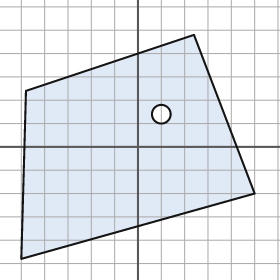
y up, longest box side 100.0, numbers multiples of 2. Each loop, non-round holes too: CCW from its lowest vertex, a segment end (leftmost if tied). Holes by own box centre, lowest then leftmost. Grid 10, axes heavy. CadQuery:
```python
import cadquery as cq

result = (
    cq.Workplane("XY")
    .moveTo(-50.0, -48.0)
    .lineTo(50.0, -20.0)
    .lineTo(24.0, 48.0)
    .lineTo(-48.0, 24.0)
    .close()
    .moveTo(10.0, 14.0)
    .circle(4.0)
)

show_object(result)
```